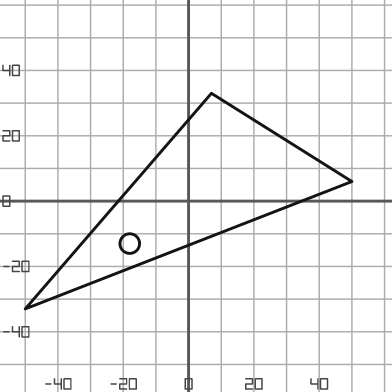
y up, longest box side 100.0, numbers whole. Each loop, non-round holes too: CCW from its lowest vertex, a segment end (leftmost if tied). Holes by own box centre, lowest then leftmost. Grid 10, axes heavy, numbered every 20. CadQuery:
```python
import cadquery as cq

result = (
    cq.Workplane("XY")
    .moveTo(-50.0, -33.0)
    .lineTo(50.0, 6.0)
    .lineTo(7.0, 33.0)
    .close()
    .moveTo(-18.0, -13.0)
    .circle(3.0)
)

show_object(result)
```